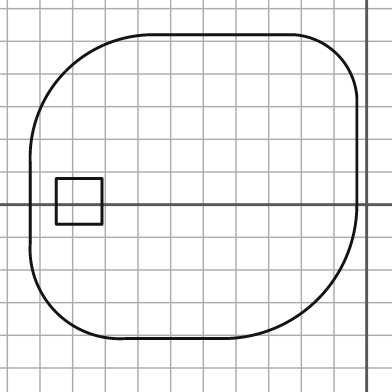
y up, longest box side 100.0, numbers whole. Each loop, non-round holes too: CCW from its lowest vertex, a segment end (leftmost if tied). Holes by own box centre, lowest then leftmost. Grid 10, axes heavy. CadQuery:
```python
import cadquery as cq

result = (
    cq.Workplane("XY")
    .moveTo(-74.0, -41.0)
    .lineTo(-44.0, -41.0)
    .threePointArc((-15.0, -29.0), (-3.0, 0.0))
    .lineTo(-3.0, 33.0)
    .threePointArc((-9.0, 46.0), (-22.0, 52.0))
    .lineTo(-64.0, 52.0)
    .threePointArc((-92.0, 41.0), (-103.0, 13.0))
    .lineTo(-103.0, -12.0)
    .threePointArc((-95.0, -33.0), (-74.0, -41.0))
    .close()
    .moveTo(-95.0, -6.0)
    .lineTo(-81.0, -6.0)
    .lineTo(-81.0, 8.0)
    .lineTo(-95.0, 8.0)
    .close()
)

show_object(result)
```